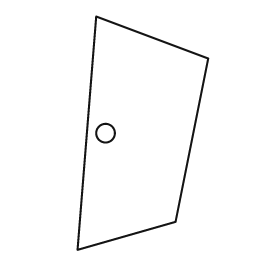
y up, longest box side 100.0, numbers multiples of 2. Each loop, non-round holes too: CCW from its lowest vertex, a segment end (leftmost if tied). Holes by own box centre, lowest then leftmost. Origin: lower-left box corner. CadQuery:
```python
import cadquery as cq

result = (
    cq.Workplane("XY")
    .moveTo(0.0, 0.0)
    .lineTo(42.0, 12.0)
    .lineTo(56.0, 82.0)
    .lineTo(8.0, 100.0)
    .close()
    .moveTo(12.0, 50.0)
    .circle(4.0)
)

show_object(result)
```